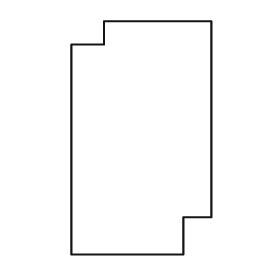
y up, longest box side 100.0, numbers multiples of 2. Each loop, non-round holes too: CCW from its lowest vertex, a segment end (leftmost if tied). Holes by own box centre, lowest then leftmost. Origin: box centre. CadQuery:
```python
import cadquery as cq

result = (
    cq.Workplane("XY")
    .moveTo(-30.0, -50.0)
    .lineTo(18.0, -50.0)
    .lineTo(18.0, -34.0)
    .lineTo(30.0, -34.0)
    .lineTo(30.0, 50.0)
    .lineTo(-16.0, 50.0)
    .lineTo(-16.0, 40.0)
    .lineTo(-30.0, 40.0)
    .close()
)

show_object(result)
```